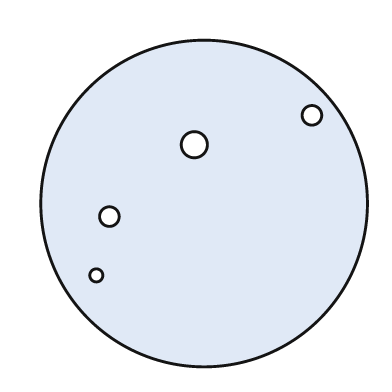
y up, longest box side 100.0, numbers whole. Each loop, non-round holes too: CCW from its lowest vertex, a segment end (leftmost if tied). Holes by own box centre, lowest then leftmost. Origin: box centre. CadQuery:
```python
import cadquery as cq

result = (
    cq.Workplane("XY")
    .moveTo(0.0, 0.0)
    .circle(50.0)
    .moveTo(-33.0, -22.0)
    .circle(2.0)
    .moveTo(-29.0, -4.0)
    .circle(3.0)
    .moveTo(-3.0, 18.0)
    .circle(4.0)
    .moveTo(33.0, 27.0)
    .circle(3.0)
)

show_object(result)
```